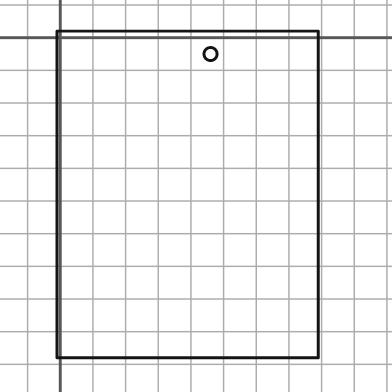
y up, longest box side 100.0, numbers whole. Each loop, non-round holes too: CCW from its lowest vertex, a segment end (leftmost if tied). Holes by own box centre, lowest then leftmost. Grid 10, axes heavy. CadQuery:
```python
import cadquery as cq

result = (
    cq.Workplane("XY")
    .moveTo(-1.0, -98.0)
    .lineTo(79.0, -98.0)
    .lineTo(79.0, 2.0)
    .lineTo(-1.0, 2.0)
    .close()
    .moveTo(46.0, -5.0)
    .circle(2.0)
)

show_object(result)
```